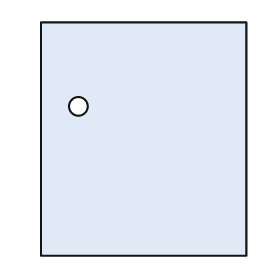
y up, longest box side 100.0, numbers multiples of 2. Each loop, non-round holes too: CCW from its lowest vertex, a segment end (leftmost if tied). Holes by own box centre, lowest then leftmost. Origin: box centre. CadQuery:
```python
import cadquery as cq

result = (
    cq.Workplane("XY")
    .moveTo(-44.0, -50.0)
    .lineTo(44.0, -50.0)
    .lineTo(44.0, 50.0)
    .lineTo(-44.0, 50.0)
    .close()
    .moveTo(-28.0, 14.0)
    .circle(4.0)
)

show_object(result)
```